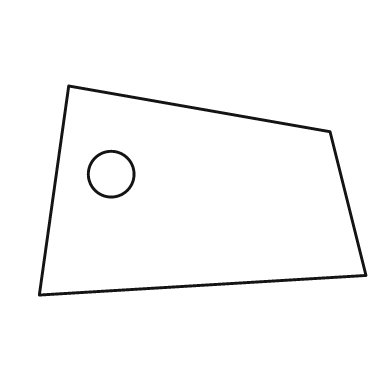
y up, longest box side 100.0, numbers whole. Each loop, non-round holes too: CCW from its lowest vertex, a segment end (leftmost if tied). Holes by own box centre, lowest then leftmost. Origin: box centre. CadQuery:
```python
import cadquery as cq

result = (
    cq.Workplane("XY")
    .moveTo(-50.0, -32.0)
    .lineTo(50.0, -26.0)
    .lineTo(39.0, 18.0)
    .lineTo(-41.0, 32.0)
    .close()
    .moveTo(-28.0, 5.0)
    .circle(7.0)
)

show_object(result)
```